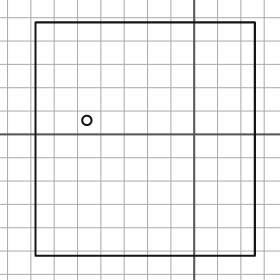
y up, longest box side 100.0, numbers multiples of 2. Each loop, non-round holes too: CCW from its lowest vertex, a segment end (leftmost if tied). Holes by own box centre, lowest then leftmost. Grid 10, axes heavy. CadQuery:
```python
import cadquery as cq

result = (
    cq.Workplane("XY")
    .moveTo(-68.0, -52.0)
    .lineTo(26.0, -52.0)
    .lineTo(26.0, 48.0)
    .lineTo(-68.0, 48.0)
    .close()
    .moveTo(-46.0, 6.0)
    .circle(2.0)
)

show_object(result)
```